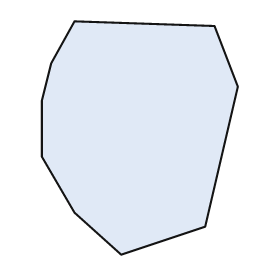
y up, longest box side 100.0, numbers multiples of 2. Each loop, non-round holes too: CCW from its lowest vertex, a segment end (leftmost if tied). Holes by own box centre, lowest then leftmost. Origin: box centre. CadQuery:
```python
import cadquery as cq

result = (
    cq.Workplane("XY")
    .moveTo(-8.0, -50.0)
    .lineTo(28.0, -38.0)
    .lineTo(42.0, 22.0)
    .lineTo(32.0, 48.0)
    .lineTo(-28.0, 50.0)
    .lineTo(-38.0, 32.0)
    .lineTo(-42.0, 16.0)
    .lineTo(-42.0, -8.0)
    .lineTo(-28.0, -32.0)
    .close()
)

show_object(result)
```